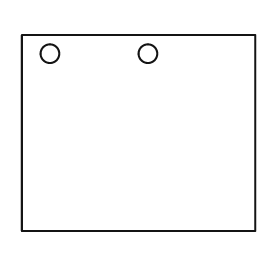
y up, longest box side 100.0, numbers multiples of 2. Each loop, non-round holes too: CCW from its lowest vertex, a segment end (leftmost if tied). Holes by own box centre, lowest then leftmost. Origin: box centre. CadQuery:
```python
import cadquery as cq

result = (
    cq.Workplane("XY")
    .moveTo(-50.0, -42.0)
    .lineTo(50.0, -42.0)
    .lineTo(50.0, 42.0)
    .lineTo(-50.0, 42.0)
    .close()
    .moveTo(-38.0, 34.0)
    .circle(4.0)
    .moveTo(4.0, 34.0)
    .circle(4.0)
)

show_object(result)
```